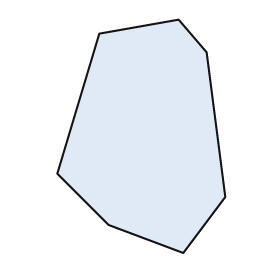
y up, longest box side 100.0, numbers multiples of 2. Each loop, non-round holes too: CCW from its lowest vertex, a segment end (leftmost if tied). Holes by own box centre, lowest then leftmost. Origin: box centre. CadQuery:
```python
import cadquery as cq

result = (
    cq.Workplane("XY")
    .moveTo(18.0, -50.0)
    .lineTo(36.0, -26.0)
    .lineTo(28.0, 36.0)
    .lineTo(16.0, 50.0)
    .lineTo(-18.0, 44.0)
    .lineTo(-36.0, -16.0)
    .lineTo(-14.0, -38.0)
    .close()
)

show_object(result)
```